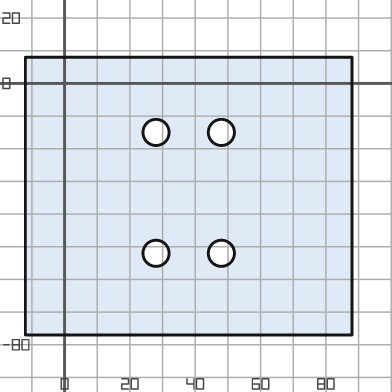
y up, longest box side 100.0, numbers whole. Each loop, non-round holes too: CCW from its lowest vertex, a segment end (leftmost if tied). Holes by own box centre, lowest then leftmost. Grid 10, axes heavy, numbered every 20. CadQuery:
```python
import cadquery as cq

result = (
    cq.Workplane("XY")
    .moveTo(-12.0, -77.0)
    .lineTo(88.0, -77.0)
    .lineTo(88.0, 8.0)
    .lineTo(-12.0, 8.0)
    .close()
    .moveTo(28.0, -52.0)
    .circle(4.0)
    .moveTo(48.0, -52.0)
    .circle(4.0)
    .moveTo(28.0, -15.0)
    .circle(4.0)
    .moveTo(48.0, -15.0)
    .circle(4.0)
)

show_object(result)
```